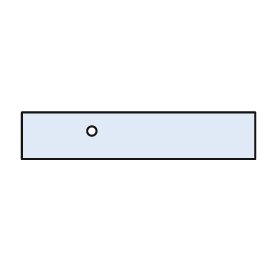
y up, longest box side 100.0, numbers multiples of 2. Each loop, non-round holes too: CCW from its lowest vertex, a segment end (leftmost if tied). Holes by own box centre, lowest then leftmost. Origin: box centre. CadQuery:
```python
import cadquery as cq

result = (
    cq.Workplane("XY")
    .moveTo(-50.0, -10.0)
    .lineTo(50.0, -10.0)
    .lineTo(50.0, 10.0)
    .lineTo(-50.0, 10.0)
    .close()
    .moveTo(-20.0, 2.0)
    .circle(2.0)
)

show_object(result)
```